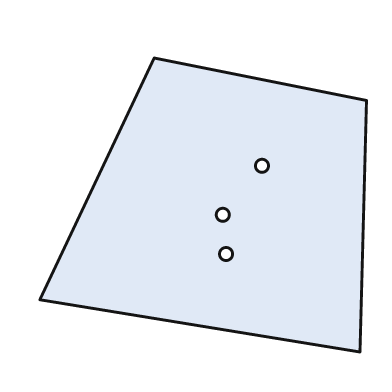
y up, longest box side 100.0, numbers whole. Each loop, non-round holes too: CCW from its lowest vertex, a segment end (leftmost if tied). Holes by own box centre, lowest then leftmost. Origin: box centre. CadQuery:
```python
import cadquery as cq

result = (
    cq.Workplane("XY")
    .moveTo(48.0, -45.0)
    .lineTo(50.0, 32.0)
    .lineTo(-15.0, 45.0)
    .lineTo(-50.0, -29.0)
    .close()
    .moveTo(7.0, -15.0)
    .circle(2.0)
    .moveTo(6.0, -3.0)
    .circle(2.0)
    .moveTo(18.0, 12.0)
    .circle(2.0)
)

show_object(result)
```